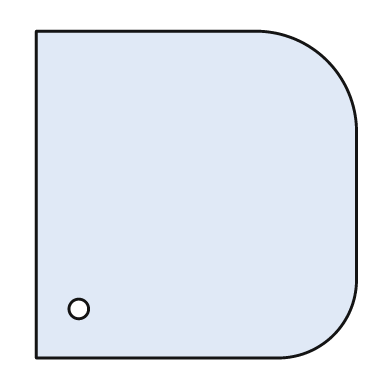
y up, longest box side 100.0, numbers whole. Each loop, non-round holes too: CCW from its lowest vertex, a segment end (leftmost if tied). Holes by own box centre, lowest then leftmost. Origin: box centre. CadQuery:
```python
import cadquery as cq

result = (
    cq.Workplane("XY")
    .moveTo(-49.0, -50.0)
    .lineTo(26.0, -50.0)
    .threePointArc((42.0, -43.0), (49.0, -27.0))
    .lineTo(49.0, 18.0)
    .threePointArc((40.0, 41.0), (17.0, 50.0))
    .lineTo(-49.0, 50.0)
    .close()
    .moveTo(-36.0, -35.0)
    .circle(3.0)
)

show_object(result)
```